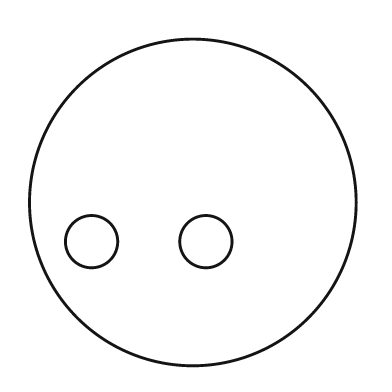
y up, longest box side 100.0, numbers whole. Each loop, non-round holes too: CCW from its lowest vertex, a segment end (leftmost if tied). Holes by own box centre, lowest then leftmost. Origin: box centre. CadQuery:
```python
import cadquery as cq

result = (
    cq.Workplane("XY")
    .moveTo(0.0, 0.0)
    .circle(50.0)
    .moveTo(-31.0, -12.0)
    .circle(8.0)
    .moveTo(4.0, -12.0)
    .circle(8.0)
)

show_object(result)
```